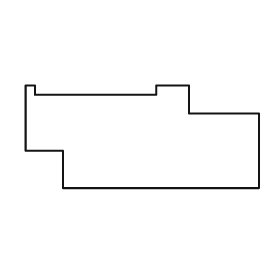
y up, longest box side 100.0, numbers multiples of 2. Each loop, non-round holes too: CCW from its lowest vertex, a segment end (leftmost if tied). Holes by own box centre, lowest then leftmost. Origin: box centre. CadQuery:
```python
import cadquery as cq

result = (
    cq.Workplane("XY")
    .moveTo(-34.0, -22.0)
    .lineTo(50.0, -22.0)
    .lineTo(50.0, 10.0)
    .lineTo(20.0, 10.0)
    .lineTo(20.0, 22.0)
    .lineTo(6.0, 22.0)
    .lineTo(6.0, 18.0)
    .lineTo(-46.0, 18.0)
    .lineTo(-46.0, 22.0)
    .lineTo(-50.0, 22.0)
    .lineTo(-50.0, -6.0)
    .lineTo(-34.0, -6.0)
    .close()
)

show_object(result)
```